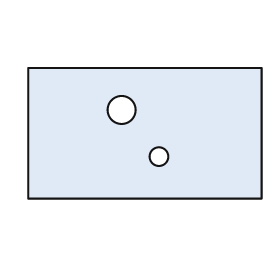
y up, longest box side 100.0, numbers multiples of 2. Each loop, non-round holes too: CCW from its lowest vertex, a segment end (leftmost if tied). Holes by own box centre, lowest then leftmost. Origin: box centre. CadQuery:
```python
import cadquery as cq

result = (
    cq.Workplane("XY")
    .moveTo(-50.0, -28.0)
    .lineTo(50.0, -28.0)
    .lineTo(50.0, 28.0)
    .lineTo(-50.0, 28.0)
    .close()
    .moveTo(6.0, -10.0)
    .circle(4.0)
    .moveTo(-10.0, 10.0)
    .circle(6.0)
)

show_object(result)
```